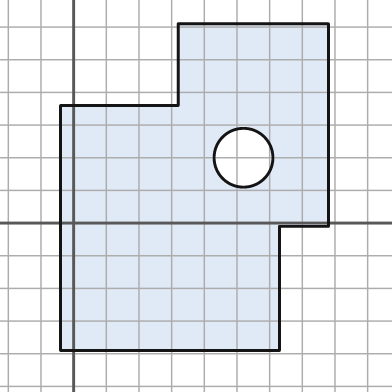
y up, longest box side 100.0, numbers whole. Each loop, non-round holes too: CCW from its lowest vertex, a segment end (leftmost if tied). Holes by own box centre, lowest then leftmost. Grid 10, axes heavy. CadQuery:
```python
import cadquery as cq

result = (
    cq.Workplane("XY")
    .moveTo(-4.0, -39.0)
    .lineTo(63.0, -39.0)
    .lineTo(63.0, -1.0)
    .lineTo(78.0, -1.0)
    .lineTo(78.0, 61.0)
    .lineTo(32.0, 61.0)
    .lineTo(32.0, 36.0)
    .lineTo(-4.0, 36.0)
    .close()
    .moveTo(52.0, 20.0)
    .circle(9.0)
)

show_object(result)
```